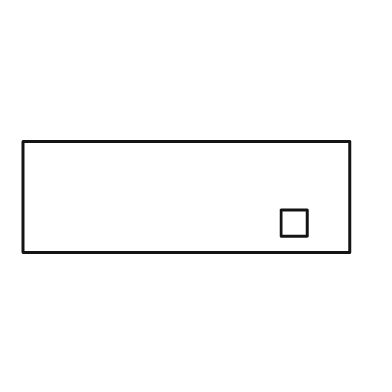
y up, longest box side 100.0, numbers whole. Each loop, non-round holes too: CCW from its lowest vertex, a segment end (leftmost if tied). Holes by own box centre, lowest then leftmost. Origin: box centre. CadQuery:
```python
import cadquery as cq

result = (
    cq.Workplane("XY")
    .moveTo(-50.0, -17.0)
    .lineTo(50.0, -17.0)
    .lineTo(50.0, 17.0)
    .lineTo(-50.0, 17.0)
    .close()
    .moveTo(29.0, -12.0)
    .lineTo(37.0, -12.0)
    .lineTo(37.0, -4.0)
    .lineTo(29.0, -4.0)
    .close()
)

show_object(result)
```